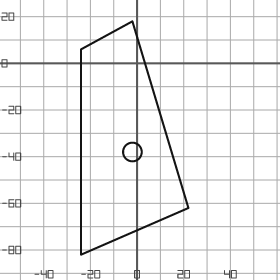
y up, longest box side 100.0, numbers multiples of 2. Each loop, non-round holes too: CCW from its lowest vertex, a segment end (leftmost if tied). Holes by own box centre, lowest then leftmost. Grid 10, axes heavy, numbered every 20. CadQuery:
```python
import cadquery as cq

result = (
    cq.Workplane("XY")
    .moveTo(-24.0, -82.0)
    .lineTo(22.0, -62.0)
    .lineTo(-2.0, 18.0)
    .lineTo(-24.0, 6.0)
    .close()
    .moveTo(-2.0, -38.0)
    .circle(4.0)
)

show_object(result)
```